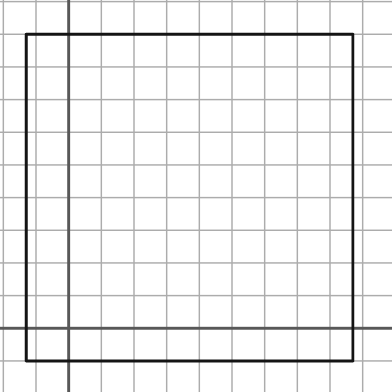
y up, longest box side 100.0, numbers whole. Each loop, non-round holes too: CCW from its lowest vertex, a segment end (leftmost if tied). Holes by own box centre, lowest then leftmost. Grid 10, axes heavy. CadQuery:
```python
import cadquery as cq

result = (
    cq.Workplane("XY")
    .moveTo(-13.0, -10.0)
    .lineTo(87.0, -10.0)
    .lineTo(87.0, 90.0)
    .lineTo(-13.0, 90.0)
    .close()
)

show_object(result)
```